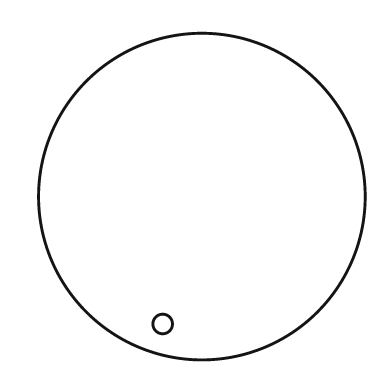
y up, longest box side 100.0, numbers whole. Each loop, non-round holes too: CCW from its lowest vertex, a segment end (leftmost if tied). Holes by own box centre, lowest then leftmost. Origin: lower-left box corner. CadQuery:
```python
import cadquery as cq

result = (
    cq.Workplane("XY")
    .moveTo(50.0, 50.0)
    .circle(50.0)
    .moveTo(38.0, 11.0)
    .circle(3.0)
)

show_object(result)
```